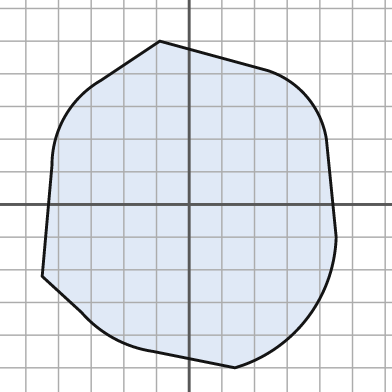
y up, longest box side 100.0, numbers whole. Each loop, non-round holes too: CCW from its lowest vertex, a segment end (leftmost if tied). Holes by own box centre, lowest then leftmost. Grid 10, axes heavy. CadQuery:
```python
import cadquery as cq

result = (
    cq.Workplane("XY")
    .moveTo(14.0, -50.0)
    .threePointArc((36.0, -35.0), (45.0, -10.0))
    .lineTo(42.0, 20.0)
    .threePointArc((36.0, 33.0), (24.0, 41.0))
    .lineTo(-9.0, 50.0)
    .lineTo(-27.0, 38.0)
    .threePointArc((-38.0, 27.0), (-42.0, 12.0))
    .lineTo(-45.0, -22.0)
    .lineTo(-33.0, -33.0)
    .threePointArc((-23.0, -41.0), (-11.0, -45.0))
    .close()
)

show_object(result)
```